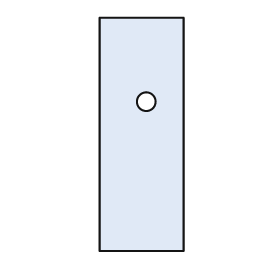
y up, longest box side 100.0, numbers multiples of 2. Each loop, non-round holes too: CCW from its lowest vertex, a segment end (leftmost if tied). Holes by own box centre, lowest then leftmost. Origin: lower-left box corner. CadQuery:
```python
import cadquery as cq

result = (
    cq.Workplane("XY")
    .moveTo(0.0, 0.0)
    .lineTo(36.0, 0.0)
    .lineTo(36.0, 100.0)
    .lineTo(0.0, 100.0)
    .close()
    .moveTo(20.0, 64.0)
    .circle(4.0)
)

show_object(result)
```